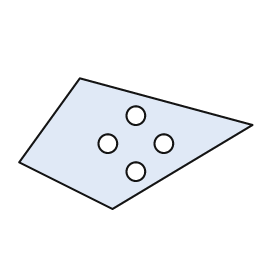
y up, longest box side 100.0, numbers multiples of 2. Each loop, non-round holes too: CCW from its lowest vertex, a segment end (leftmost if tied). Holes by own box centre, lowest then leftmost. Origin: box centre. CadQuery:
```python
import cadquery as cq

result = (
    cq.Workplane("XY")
    .moveTo(-10.0, -28.0)
    .lineTo(50.0, 8.0)
    .lineTo(-24.0, 28.0)
    .lineTo(-50.0, -8.0)
    .close()
    .moveTo(0.0, -12.0)
    .circle(4.0)
    .moveTo(-12.0, 0.0)
    .circle(4.0)
    .moveTo(12.0, 0.0)
    .circle(4.0)
    .moveTo(0.0, 12.0)
    .circle(4.0)
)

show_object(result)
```